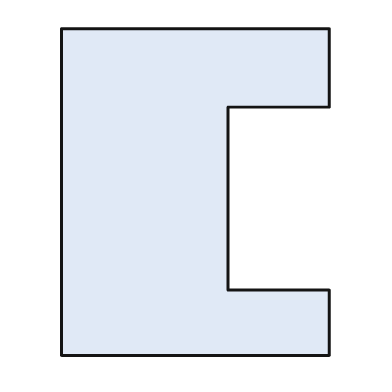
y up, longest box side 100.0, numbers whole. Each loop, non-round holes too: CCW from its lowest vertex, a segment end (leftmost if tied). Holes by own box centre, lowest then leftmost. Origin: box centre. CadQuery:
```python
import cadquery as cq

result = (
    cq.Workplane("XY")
    .moveTo(-41.0, -50.0)
    .lineTo(41.0, -50.0)
    .lineTo(41.0, -30.0)
    .lineTo(10.0, -30.0)
    .lineTo(10.0, 26.0)
    .lineTo(41.0, 26.0)
    .lineTo(41.0, 50.0)
    .lineTo(-41.0, 50.0)
    .close()
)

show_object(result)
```